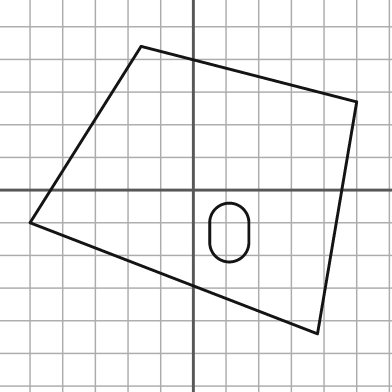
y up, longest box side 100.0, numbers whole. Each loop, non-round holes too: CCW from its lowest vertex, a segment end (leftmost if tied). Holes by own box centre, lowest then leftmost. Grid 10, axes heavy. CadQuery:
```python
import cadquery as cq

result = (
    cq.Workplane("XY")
    .moveTo(38.0, -44.0)
    .lineTo(50.0, 27.0)
    .lineTo(-16.0, 44.0)
    .lineTo(-50.0, -10.0)
    .close()
    .moveTo(5.0, -16.0)
    .threePointArc((11.0, -22.0), (17.0, -16.0))
    .lineTo(17.0, -10.0)
    .threePointArc((11.0, -4.0), (5.0, -10.0))
    .close()
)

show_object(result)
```